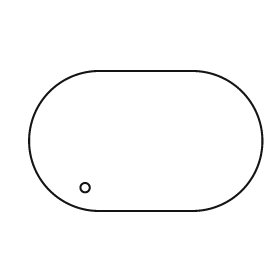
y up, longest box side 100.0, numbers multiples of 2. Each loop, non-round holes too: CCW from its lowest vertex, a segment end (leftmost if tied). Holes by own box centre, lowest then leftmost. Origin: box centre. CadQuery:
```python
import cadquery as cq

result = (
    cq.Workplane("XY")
    .moveTo(-20.0, -30.0)
    .lineTo(20.0, -30.0)
    .threePointArc((50.0, 0.0), (20.0, 30.0))
    .lineTo(-20.0, 30.0)
    .threePointArc((-50.0, 0.0), (-20.0, -30.0))
    .close()
    .moveTo(-26.0, -20.0)
    .circle(2.0)
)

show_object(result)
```